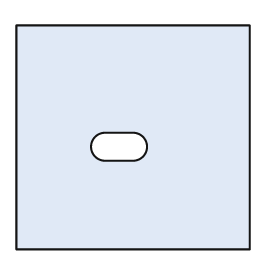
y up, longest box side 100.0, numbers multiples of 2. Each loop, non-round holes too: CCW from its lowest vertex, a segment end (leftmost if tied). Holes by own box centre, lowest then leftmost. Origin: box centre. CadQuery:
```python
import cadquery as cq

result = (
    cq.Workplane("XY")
    .moveTo(-50.0, -48.0)
    .lineTo(50.0, -48.0)
    .lineTo(50.0, 48.0)
    .lineTo(-50.0, 48.0)
    .close()
    .moveTo(-12.0, -10.0)
    .lineTo(0.0, -10.0)
    .threePointArc((6.0, -4.0), (0.0, 2.0))
    .lineTo(-12.0, 2.0)
    .threePointArc((-18.0, -4.0), (-12.0, -10.0))
    .close()
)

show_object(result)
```